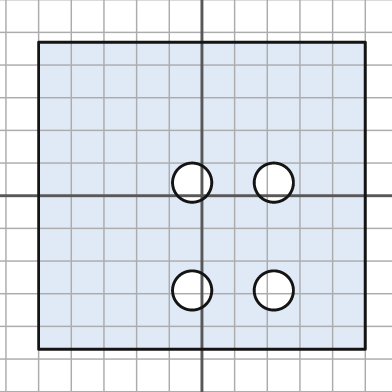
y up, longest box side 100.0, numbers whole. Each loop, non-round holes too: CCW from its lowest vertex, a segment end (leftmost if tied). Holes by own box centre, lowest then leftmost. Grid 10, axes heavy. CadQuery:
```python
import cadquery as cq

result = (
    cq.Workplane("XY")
    .moveTo(-50.0, -47.0)
    .lineTo(50.0, -47.0)
    .lineTo(50.0, 47.0)
    .lineTo(-50.0, 47.0)
    .close()
    .moveTo(-3.0, -29.0)
    .circle(6.0)
    .moveTo(22.0, -29.0)
    .circle(6.0)
    .moveTo(-3.0, 4.0)
    .circle(6.0)
    .moveTo(22.0, 4.0)
    .circle(6.0)
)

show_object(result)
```